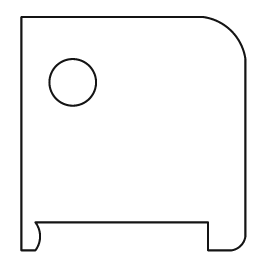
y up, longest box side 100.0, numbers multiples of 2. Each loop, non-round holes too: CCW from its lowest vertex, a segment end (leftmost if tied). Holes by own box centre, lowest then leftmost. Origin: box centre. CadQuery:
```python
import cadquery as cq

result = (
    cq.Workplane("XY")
    .moveTo(-48.0, -50.0)
    .lineTo(-42.0, -50.0)
    .threePointArc((-40.0, -44.0), (-42.0, -38.0))
    .lineTo(32.0, -38.0)
    .lineTo(32.0, -50.0)
    .lineTo(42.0, -50.0)
    .threePointArc((46.0, -48.0), (48.0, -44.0))
    .lineTo(48.0, 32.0)
    .threePointArc((42.0, 44.0), (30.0, 50.0))
    .lineTo(-48.0, 50.0)
    .close()
    .moveTo(-26.0, 22.0)
    .circle(10.0)
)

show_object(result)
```